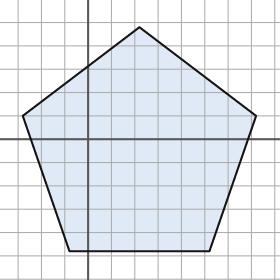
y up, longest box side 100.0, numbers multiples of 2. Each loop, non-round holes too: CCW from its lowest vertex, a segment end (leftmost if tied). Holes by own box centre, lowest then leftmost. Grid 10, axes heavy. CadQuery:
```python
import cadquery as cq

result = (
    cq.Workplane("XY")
    .moveTo(-8.0, -48.0)
    .lineTo(52.0, -48.0)
    .lineTo(72.0, 10.0)
    .lineTo(22.0, 48.0)
    .lineTo(-28.0, 10.0)
    .close()
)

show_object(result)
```